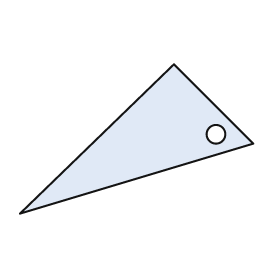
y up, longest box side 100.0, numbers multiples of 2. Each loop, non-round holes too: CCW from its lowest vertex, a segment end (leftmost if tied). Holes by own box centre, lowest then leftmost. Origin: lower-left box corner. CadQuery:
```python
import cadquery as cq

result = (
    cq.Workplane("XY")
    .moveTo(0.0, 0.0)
    .lineTo(100.0, 30.0)
    .lineTo(66.0, 64.0)
    .close()
    .moveTo(84.0, 34.0)
    .circle(4.0)
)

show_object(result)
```